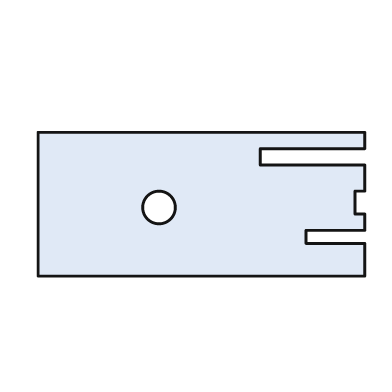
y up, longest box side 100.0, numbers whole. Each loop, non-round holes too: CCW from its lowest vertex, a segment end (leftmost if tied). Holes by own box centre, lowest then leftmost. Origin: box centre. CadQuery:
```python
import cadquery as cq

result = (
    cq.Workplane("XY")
    .moveTo(-50.0, -22.0)
    .lineTo(50.0, -22.0)
    .lineTo(50.0, -12.0)
    .lineTo(32.0, -12.0)
    .lineTo(32.0, -8.0)
    .lineTo(50.0, -8.0)
    .lineTo(50.0, -3.0)
    .lineTo(47.0, -3.0)
    .lineTo(47.0, 4.0)
    .lineTo(50.0, 4.0)
    .lineTo(50.0, 12.0)
    .lineTo(18.0, 12.0)
    .lineTo(18.0, 17.0)
    .lineTo(50.0, 17.0)
    .lineTo(50.0, 22.0)
    .lineTo(-50.0, 22.0)
    .close()
    .moveTo(-13.0, -1.0)
    .circle(5.0)
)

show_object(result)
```